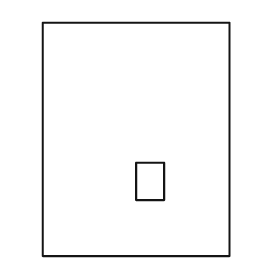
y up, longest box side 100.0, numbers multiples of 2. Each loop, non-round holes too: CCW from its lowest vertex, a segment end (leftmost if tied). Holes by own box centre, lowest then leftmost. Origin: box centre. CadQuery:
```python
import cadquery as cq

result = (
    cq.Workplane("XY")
    .moveTo(-40.0, -50.0)
    .lineTo(40.0, -50.0)
    .lineTo(40.0, 50.0)
    .lineTo(-40.0, 50.0)
    .close()
    .moveTo(0.0, -26.0)
    .lineTo(12.0, -26.0)
    .lineTo(12.0, -10.0)
    .lineTo(0.0, -10.0)
    .close()
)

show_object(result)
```